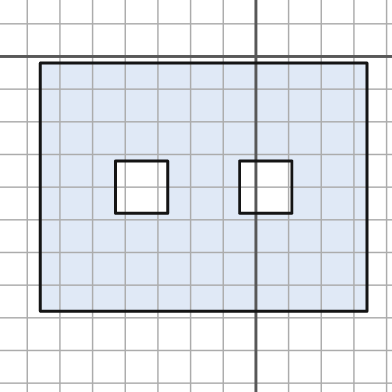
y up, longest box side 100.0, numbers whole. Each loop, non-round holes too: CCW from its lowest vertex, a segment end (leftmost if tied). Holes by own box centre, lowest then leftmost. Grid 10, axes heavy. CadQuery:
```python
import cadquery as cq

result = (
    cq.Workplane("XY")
    .moveTo(-66.0, -78.0)
    .lineTo(34.0, -78.0)
    .lineTo(34.0, -2.0)
    .lineTo(-66.0, -2.0)
    .close()
    .moveTo(-43.0, -48.0)
    .lineTo(-27.0, -48.0)
    .lineTo(-27.0, -32.0)
    .lineTo(-43.0, -32.0)
    .close()
    .moveTo(-5.0, -48.0)
    .lineTo(11.0, -48.0)
    .lineTo(11.0, -32.0)
    .lineTo(-5.0, -32.0)
    .close()
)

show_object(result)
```